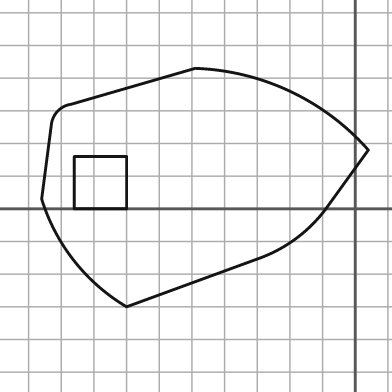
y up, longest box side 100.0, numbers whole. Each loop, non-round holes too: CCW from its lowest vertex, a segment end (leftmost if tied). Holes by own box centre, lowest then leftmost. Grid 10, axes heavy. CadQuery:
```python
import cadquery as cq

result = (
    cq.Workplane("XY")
    .moveTo(-70.0, -30.0)
    .lineTo(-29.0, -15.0)
    .threePointArc((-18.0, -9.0), (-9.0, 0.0))
    .lineTo(4.0, 18.0)
    .threePointArc((-20.0, 36.0), (-49.0, 43.0))
    .lineTo(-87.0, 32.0)
    .threePointArc((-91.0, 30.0), (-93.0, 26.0))
    .lineTo(-96.0, 3.0)
    .threePointArc((-86.0, -16.0), (-70.0, -30.0))
    .close()
    .moveTo(-86.0, 0.0)
    .lineTo(-70.0, 0.0)
    .lineTo(-70.0, 16.0)
    .lineTo(-86.0, 16.0)
    .close()
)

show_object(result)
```